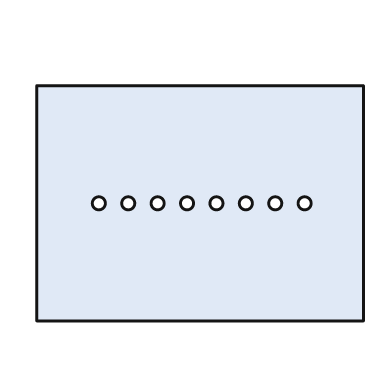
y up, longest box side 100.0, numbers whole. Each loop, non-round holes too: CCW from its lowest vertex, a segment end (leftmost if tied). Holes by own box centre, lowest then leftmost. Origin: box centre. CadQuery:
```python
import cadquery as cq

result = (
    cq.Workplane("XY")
    .moveTo(-50.0, -36.0)
    .lineTo(50.0, -36.0)
    .lineTo(50.0, 36.0)
    .lineTo(-50.0, 36.0)
    .close()
    .moveTo(-31.0, 0.0)
    .circle(2.0)
    .moveTo(-22.0, 0.0)
    .circle(2.0)
    .moveTo(-13.0, 0.0)
    .circle(2.0)
    .moveTo(-4.0, 0.0)
    .circle(2.0)
    .moveTo(5.0, 0.0)
    .circle(2.0)
    .moveTo(14.0, 0.0)
    .circle(2.0)
    .moveTo(23.0, 0.0)
    .circle(2.0)
    .moveTo(32.0, 0.0)
    .circle(2.0)
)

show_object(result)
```